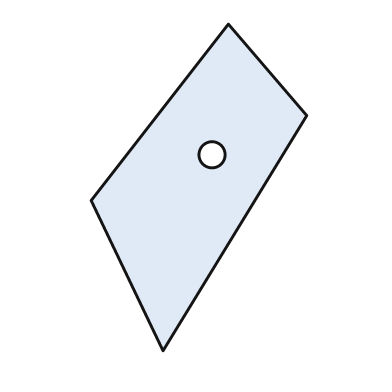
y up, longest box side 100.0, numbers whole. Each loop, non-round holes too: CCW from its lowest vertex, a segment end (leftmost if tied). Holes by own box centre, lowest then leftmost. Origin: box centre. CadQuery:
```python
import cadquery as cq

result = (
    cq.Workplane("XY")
    .moveTo(-11.0, -50.0)
    .lineTo(33.0, 22.0)
    .lineTo(9.0, 50.0)
    .lineTo(-33.0, -4.0)
    .close()
    .moveTo(4.0, 10.0)
    .circle(4.0)
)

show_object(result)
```